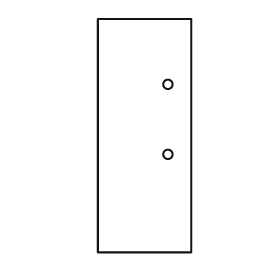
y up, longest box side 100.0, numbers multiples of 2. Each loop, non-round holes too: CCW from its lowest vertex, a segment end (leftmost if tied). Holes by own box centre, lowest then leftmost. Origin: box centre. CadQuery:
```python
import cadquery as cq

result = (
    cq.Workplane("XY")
    .moveTo(-20.0, -50.0)
    .lineTo(20.0, -50.0)
    .lineTo(20.0, 50.0)
    .lineTo(-20.0, 50.0)
    .close()
    .moveTo(10.0, -8.0)
    .circle(2.0)
    .moveTo(10.0, 22.0)
    .circle(2.0)
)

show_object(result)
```